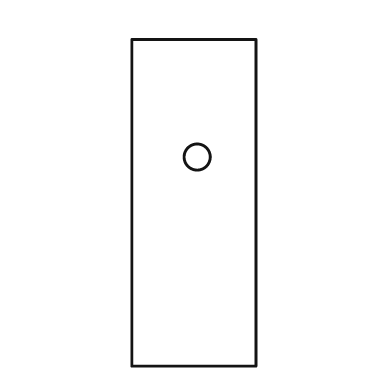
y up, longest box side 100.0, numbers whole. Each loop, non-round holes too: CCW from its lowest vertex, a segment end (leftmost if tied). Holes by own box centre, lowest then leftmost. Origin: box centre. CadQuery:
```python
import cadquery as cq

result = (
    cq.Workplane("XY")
    .moveTo(-19.0, -50.0)
    .lineTo(19.0, -50.0)
    .lineTo(19.0, 50.0)
    .lineTo(-19.0, 50.0)
    .close()
    .moveTo(1.0, 14.0)
    .circle(4.0)
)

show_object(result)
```